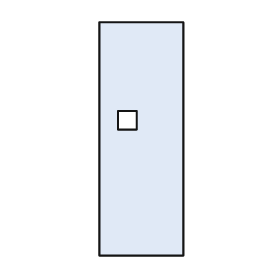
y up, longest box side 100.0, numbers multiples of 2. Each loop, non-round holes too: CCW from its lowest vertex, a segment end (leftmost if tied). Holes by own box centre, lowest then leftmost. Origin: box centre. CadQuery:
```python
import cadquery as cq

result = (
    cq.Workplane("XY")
    .moveTo(-18.0, -50.0)
    .lineTo(18.0, -50.0)
    .lineTo(18.0, 50.0)
    .lineTo(-18.0, 50.0)
    .close()
    .moveTo(-10.0, 4.0)
    .lineTo(-2.0, 4.0)
    .lineTo(-2.0, 12.0)
    .lineTo(-10.0, 12.0)
    .close()
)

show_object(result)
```